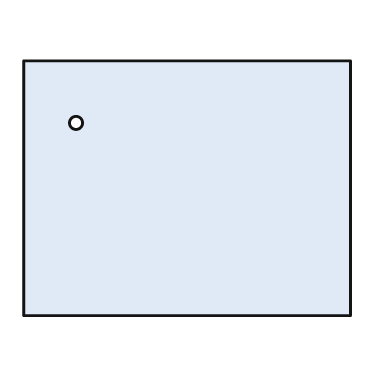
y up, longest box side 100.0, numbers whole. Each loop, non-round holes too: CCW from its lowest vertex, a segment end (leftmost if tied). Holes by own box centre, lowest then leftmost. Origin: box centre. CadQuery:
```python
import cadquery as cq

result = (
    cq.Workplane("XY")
    .moveTo(-50.0, -39.0)
    .lineTo(50.0, -39.0)
    .lineTo(50.0, 39.0)
    .lineTo(-50.0, 39.0)
    .close()
    .moveTo(-34.0, 20.0)
    .circle(2.0)
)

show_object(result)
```